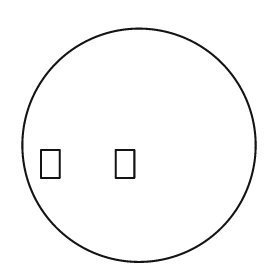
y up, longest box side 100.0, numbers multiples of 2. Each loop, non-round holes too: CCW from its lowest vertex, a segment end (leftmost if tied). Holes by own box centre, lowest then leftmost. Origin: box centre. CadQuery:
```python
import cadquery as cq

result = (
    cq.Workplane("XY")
    .moveTo(0.0, 0.0)
    .circle(50.0)
    .moveTo(-42.0, -14.0)
    .lineTo(-34.0, -14.0)
    .lineTo(-34.0, -2.0)
    .lineTo(-42.0, -2.0)
    .close()
    .moveTo(-10.0, -14.0)
    .lineTo(-2.0, -14.0)
    .lineTo(-2.0, -2.0)
    .lineTo(-10.0, -2.0)
    .close()
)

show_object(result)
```